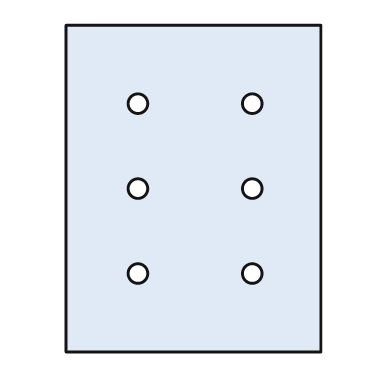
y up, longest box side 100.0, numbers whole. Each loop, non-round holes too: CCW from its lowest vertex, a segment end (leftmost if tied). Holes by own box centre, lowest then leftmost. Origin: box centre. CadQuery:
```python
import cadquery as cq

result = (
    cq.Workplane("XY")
    .moveTo(-39.0, -50.0)
    .lineTo(39.0, -50.0)
    .lineTo(39.0, 50.0)
    .lineTo(-39.0, 50.0)
    .close()
    .moveTo(-17.0, -26.0)
    .circle(3.0)
    .moveTo(18.0, -26.0)
    .circle(3.0)
    .moveTo(-17.0, 0.0)
    .circle(3.0)
    .moveTo(18.0, 0.0)
    .circle(3.0)
    .moveTo(-17.0, 26.0)
    .circle(3.0)
    .moveTo(18.0, 26.0)
    .circle(3.0)
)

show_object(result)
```